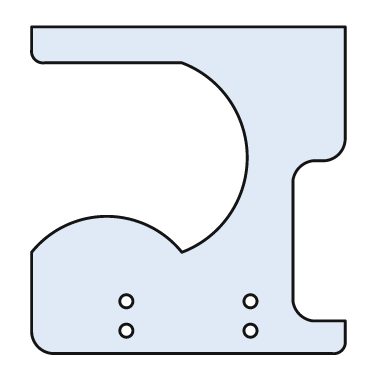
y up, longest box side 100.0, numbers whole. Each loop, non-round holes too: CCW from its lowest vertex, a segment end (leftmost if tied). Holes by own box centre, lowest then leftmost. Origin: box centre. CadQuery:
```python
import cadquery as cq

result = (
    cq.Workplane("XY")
    .moveTo(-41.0, -50.0)
    .lineTo(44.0, -50.0)
    .threePointArc((47.0, -49.0), (48.0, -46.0))
    .lineTo(48.0, -40.0)
    .lineTo(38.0, -40.0)
    .threePointArc((34.0, -38.0), (32.0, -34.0))
    .lineTo(32.0, 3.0)
    .threePointArc((34.0, 7.0), (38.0, 9.0))
    .lineTo(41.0, 9.0)
    .threePointArc((46.0, 11.0), (48.0, 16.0))
    .lineTo(48.0, 50.0)
    .lineTo(-48.0, 50.0)
    .lineTo(-48.0, 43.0)
    .threePointArc((-47.0, 40.0), (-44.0, 39.0))
    .lineTo(-2.0, 39.0)
    .threePointArc((18.0, 10.0), (-2.0, -19.0))
    .threePointArc((-25.0, -8.0), (-48.0, -19.0))
    .lineTo(-48.0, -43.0)
    .threePointArc((-46.0, -48.0), (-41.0, -50.0))
    .close()
    .moveTo(-19.0, -43.0)
    .circle(2.0)
    .moveTo(19.0, -43.0)
    .circle(2.0)
    .moveTo(-19.0, -34.0)
    .circle(2.0)
    .moveTo(19.0, -34.0)
    .circle(2.0)
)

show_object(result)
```